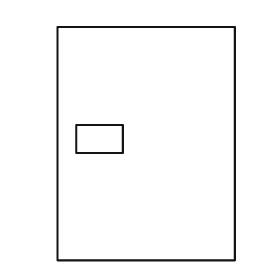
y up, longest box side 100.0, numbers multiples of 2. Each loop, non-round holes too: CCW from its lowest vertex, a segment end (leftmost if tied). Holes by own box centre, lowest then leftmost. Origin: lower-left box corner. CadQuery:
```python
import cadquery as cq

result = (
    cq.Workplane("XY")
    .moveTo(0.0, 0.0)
    .lineTo(76.0, 0.0)
    .lineTo(76.0, 100.0)
    .lineTo(0.0, 100.0)
    .close()
    .moveTo(8.0, 46.0)
    .lineTo(28.0, 46.0)
    .lineTo(28.0, 58.0)
    .lineTo(8.0, 58.0)
    .close()
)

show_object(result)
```